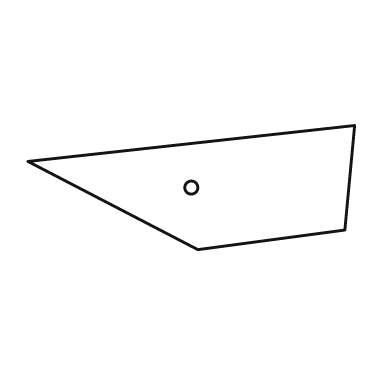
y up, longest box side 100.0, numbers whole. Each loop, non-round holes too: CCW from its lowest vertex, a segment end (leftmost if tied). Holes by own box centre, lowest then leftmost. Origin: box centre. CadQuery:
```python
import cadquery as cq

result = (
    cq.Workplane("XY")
    .moveTo(2.0, -19.0)
    .lineTo(47.0, -13.0)
    .lineTo(50.0, 19.0)
    .lineTo(-50.0, 8.0)
    .close()
    .moveTo(0.0, 0.0)
    .circle(2.0)
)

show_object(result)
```